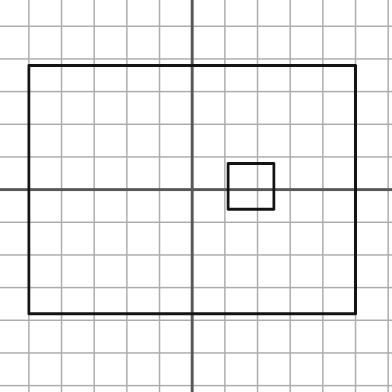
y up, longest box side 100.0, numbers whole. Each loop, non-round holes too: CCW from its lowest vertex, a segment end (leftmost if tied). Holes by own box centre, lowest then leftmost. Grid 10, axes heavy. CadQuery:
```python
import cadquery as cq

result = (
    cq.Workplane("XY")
    .moveTo(-50.0, -38.0)
    .lineTo(50.0, -38.0)
    .lineTo(50.0, 38.0)
    .lineTo(-50.0, 38.0)
    .close()
    .moveTo(11.0, -6.0)
    .lineTo(25.0, -6.0)
    .lineTo(25.0, 8.0)
    .lineTo(11.0, 8.0)
    .close()
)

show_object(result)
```